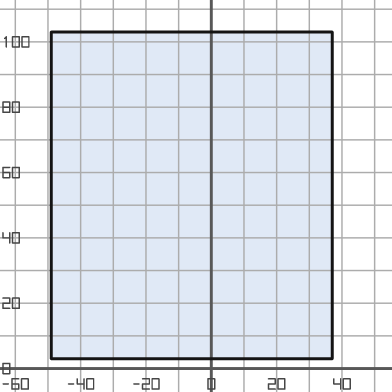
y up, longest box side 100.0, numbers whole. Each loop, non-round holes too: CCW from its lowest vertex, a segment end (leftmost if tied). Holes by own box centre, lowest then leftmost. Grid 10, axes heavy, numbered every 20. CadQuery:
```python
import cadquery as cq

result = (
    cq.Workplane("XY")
    .moveTo(-49.0, 3.0)
    .lineTo(37.0, 3.0)
    .lineTo(37.0, 103.0)
    .lineTo(-49.0, 103.0)
    .close()
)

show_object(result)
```